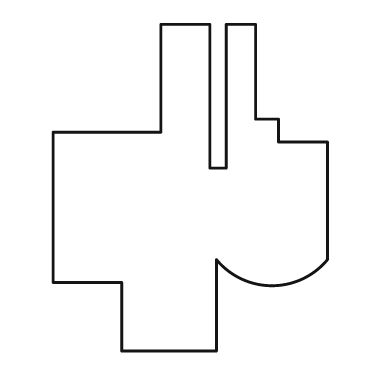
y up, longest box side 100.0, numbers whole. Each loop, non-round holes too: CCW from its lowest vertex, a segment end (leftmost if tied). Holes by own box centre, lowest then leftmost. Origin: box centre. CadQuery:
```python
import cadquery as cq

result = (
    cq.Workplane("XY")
    .moveTo(-21.0, -50.0)
    .lineTo(8.0, -50.0)
    .lineTo(8.0, -22.0)
    .threePointArc((25.0, -30.0), (42.0, -22.0))
    .lineTo(42.0, 14.0)
    .lineTo(27.0, 14.0)
    .lineTo(27.0, 21.0)
    .lineTo(20.0, 21.0)
    .lineTo(20.0, 50.0)
    .lineTo(11.0, 50.0)
    .lineTo(11.0, 6.0)
    .lineTo(6.0, 6.0)
    .lineTo(6.0, 50.0)
    .lineTo(-9.0, 50.0)
    .lineTo(-9.0, 17.0)
    .lineTo(-42.0, 17.0)
    .lineTo(-42.0, -29.0)
    .lineTo(-21.0, -29.0)
    .close()
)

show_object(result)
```